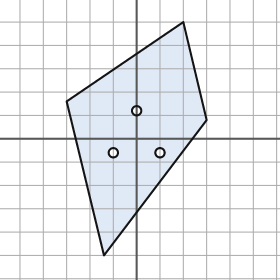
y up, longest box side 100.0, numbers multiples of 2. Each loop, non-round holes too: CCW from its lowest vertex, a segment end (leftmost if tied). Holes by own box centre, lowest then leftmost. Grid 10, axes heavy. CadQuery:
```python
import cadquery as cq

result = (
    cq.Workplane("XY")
    .moveTo(-14.0, -50.0)
    .lineTo(30.0, 8.0)
    .lineTo(20.0, 50.0)
    .lineTo(-30.0, 16.0)
    .close()
    .moveTo(-10.0, -6.0)
    .circle(2.0)
    .moveTo(10.0, -6.0)
    .circle(2.0)
    .moveTo(0.0, 12.0)
    .circle(2.0)
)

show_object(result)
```